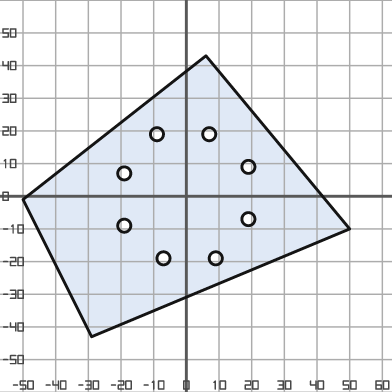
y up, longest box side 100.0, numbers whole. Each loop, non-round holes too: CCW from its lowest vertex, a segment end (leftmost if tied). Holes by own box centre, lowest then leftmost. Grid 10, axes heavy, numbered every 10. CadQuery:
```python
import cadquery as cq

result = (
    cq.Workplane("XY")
    .moveTo(-29.0, -43.0)
    .lineTo(50.0, -10.0)
    .lineTo(6.0, 43.0)
    .lineTo(-50.0, -1.0)
    .close()
    .moveTo(-7.0, -19.0)
    .circle(2.0)
    .moveTo(9.0, -19.0)
    .circle(2.0)
    .moveTo(-19.0, -9.0)
    .circle(2.0)
    .moveTo(19.0, -7.0)
    .circle(2.0)
    .moveTo(-19.0, 7.0)
    .circle(2.0)
    .moveTo(19.0, 9.0)
    .circle(2.0)
    .moveTo(-9.0, 19.0)
    .circle(2.0)
    .moveTo(7.0, 19.0)
    .circle(2.0)
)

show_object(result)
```